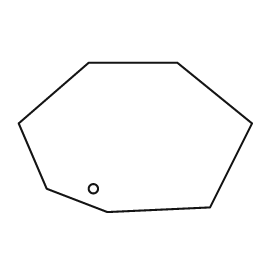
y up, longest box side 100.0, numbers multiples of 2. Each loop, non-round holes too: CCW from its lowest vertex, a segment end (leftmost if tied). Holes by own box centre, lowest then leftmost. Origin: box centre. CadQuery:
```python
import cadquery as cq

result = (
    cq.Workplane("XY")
    .moveTo(-12.0, -32.0)
    .lineTo(32.0, -30.0)
    .lineTo(50.0, 6.0)
    .lineTo(18.0, 32.0)
    .lineTo(-20.0, 32.0)
    .lineTo(-50.0, 6.0)
    .lineTo(-38.0, -22.0)
    .close()
    .moveTo(-18.0, -22.0)
    .circle(2.0)
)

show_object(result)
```